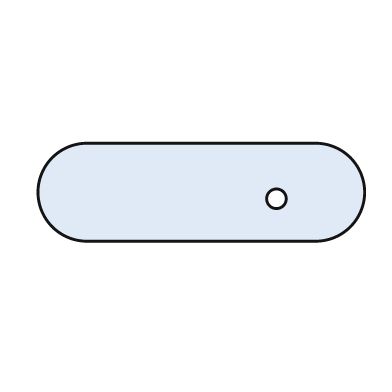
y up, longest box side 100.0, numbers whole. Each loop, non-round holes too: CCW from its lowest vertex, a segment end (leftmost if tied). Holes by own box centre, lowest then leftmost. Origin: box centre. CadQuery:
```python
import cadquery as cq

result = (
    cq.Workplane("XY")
    .moveTo(-35.0, -15.0)
    .lineTo(35.0, -15.0)
    .threePointArc((50.0, 0.0), (35.0, 15.0))
    .lineTo(-35.0, 15.0)
    .threePointArc((-50.0, 0.0), (-35.0, -15.0))
    .close()
    .moveTo(23.0, -2.0)
    .circle(3.0)
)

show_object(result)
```